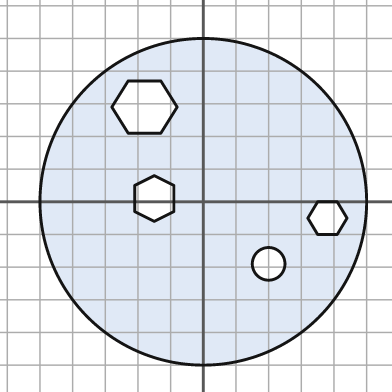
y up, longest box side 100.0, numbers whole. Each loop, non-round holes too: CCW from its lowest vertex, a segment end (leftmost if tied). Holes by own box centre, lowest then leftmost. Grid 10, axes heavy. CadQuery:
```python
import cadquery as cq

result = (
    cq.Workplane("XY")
    .moveTo(0.0, 0.0)
    .circle(50.0)
    .moveTo(20.0, -19.0)
    .circle(5.0)
    .moveTo(35.0, -10.0)
    .lineTo(41.0, -10.0)
    .lineTo(44.0, -5.0)
    .lineTo(41.0, 0.0)
    .lineTo(35.0, 0.0)
    .lineTo(32.0, -5.0)
    .close()
    .moveTo(-15.0, -6.0)
    .lineTo(-9.0, -3.0)
    .lineTo(-9.0, 5.0)
    .lineTo(-15.0, 8.0)
    .lineTo(-21.0, 5.0)
    .lineTo(-21.0, -3.0)
    .close()
    .moveTo(-23.0, 21.0)
    .lineTo(-13.0, 21.0)
    .lineTo(-8.0, 29.0)
    .lineTo(-13.0, 37.0)
    .lineTo(-23.0, 37.0)
    .lineTo(-28.0, 29.0)
    .close()
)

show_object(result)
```